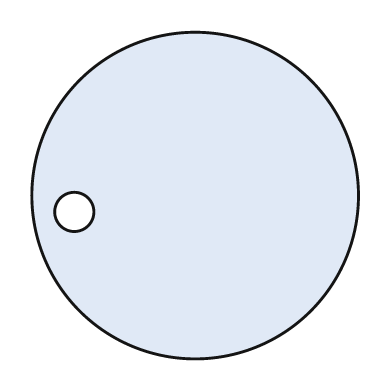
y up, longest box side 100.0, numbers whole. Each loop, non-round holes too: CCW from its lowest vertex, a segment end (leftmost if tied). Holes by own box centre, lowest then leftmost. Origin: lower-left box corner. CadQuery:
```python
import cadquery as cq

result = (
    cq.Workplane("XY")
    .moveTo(50.0, 50.0)
    .circle(50.0)
    .moveTo(13.0, 45.0)
    .circle(6.0)
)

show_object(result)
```